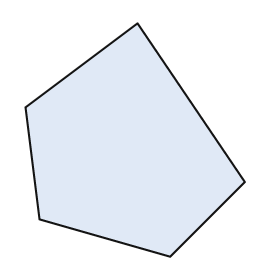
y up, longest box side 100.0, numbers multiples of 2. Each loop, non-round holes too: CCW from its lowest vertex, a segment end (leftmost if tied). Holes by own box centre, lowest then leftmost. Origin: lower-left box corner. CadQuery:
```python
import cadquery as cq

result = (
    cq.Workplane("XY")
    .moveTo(62.0, 0.0)
    .lineTo(94.0, 32.0)
    .lineTo(48.0, 100.0)
    .lineTo(0.0, 64.0)
    .lineTo(6.0, 16.0)
    .close()
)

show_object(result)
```